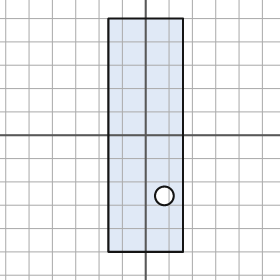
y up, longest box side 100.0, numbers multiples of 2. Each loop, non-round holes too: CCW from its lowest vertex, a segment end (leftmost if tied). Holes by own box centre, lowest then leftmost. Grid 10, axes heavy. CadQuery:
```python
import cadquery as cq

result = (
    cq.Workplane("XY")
    .moveTo(-16.0, -50.0)
    .lineTo(16.0, -50.0)
    .lineTo(16.0, 50.0)
    .lineTo(-16.0, 50.0)
    .close()
    .moveTo(8.0, -26.0)
    .circle(4.0)
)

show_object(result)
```